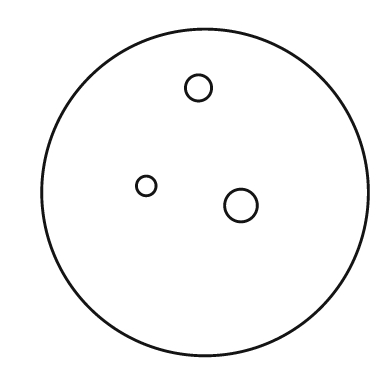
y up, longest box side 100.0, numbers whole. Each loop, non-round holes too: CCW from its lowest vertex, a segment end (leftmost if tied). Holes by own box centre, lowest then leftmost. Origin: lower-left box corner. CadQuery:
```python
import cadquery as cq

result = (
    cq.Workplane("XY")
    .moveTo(50.0, 50.0)
    .circle(50.0)
    .moveTo(61.0, 46.0)
    .circle(5.0)
    .moveTo(32.0, 52.0)
    .circle(3.0)
    .moveTo(48.0, 82.0)
    .circle(4.0)
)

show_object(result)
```